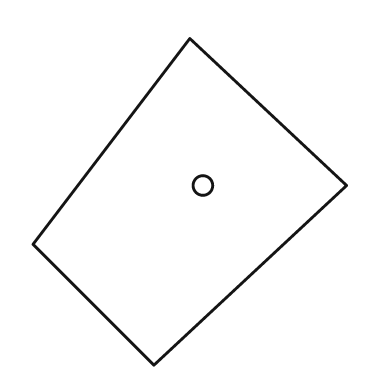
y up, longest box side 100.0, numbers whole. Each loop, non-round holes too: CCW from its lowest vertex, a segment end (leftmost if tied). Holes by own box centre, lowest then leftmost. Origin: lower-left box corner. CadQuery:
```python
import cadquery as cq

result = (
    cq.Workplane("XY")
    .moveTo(37.0, 0.0)
    .lineTo(96.0, 55.0)
    .lineTo(48.0, 100.0)
    .lineTo(0.0, 37.0)
    .close()
    .moveTo(52.0, 55.0)
    .circle(3.0)
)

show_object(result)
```